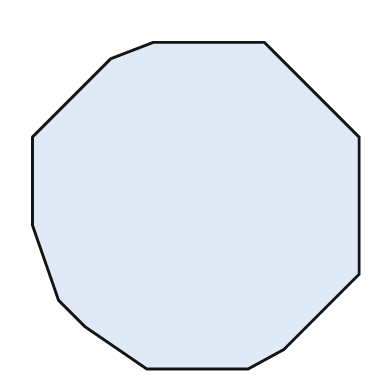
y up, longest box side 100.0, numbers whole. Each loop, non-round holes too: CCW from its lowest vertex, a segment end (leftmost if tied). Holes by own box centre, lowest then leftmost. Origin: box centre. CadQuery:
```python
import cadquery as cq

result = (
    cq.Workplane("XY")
    .moveTo(-15.0, -50.0)
    .lineTo(16.0, -50.0)
    .lineTo(27.0, -44.0)
    .lineTo(50.0, -21.0)
    .lineTo(50.0, 21.0)
    .lineTo(21.0, 50.0)
    .lineTo(-13.0, 50.0)
    .lineTo(-26.0, 45.0)
    .lineTo(-50.0, 21.0)
    .lineTo(-50.0, -6.0)
    .lineTo(-42.0, -29.0)
    .lineTo(-34.0, -37.0)
    .close()
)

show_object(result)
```